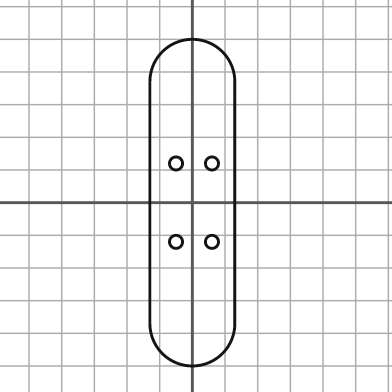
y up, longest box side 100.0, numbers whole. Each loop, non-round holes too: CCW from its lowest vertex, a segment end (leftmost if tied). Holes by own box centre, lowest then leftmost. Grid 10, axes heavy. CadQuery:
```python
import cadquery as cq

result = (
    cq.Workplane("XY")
    .moveTo(-13.0, -37.0)
    .threePointArc((0.0, -50.0), (13.0, -37.0))
    .lineTo(13.0, 37.0)
    .threePointArc((0.0, 50.0), (-13.0, 37.0))
    .close()
    .moveTo(-5.0, -12.0)
    .circle(2.0)
    .moveTo(6.0, -12.0)
    .circle(2.0)
    .moveTo(-5.0, 12.0)
    .circle(2.0)
    .moveTo(6.0, 12.0)
    .circle(2.0)
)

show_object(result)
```